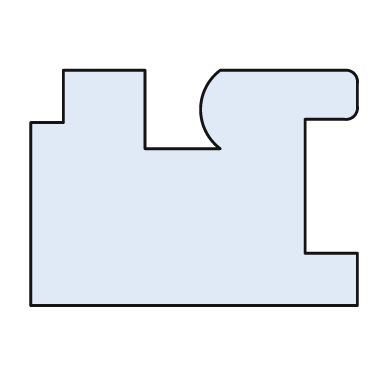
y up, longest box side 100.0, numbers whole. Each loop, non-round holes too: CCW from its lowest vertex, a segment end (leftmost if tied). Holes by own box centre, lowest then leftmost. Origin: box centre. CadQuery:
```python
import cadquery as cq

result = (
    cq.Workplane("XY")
    .moveTo(-50.0, -36.0)
    .lineTo(50.0, -36.0)
    .lineTo(50.0, -20.0)
    .lineTo(34.0, -20.0)
    .lineTo(34.0, 21.0)
    .lineTo(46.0, 21.0)
    .threePointArc((49.0, 22.0), (50.0, 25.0))
    .lineTo(50.0, 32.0)
    .threePointArc((49.0, 35.0), (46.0, 36.0))
    .lineTo(8.0, 36.0)
    .threePointArc((2.0, 24.0), (8.0, 12.0))
    .lineTo(-15.0, 12.0)
    .lineTo(-15.0, 36.0)
    .lineTo(-40.0, 36.0)
    .lineTo(-40.0, 20.0)
    .lineTo(-50.0, 20.0)
    .close()
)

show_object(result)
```